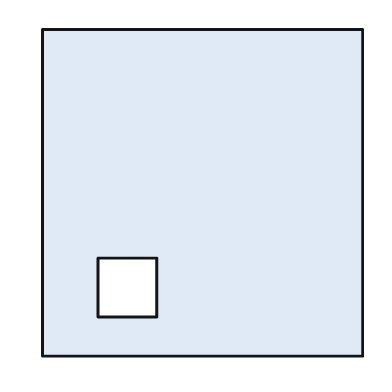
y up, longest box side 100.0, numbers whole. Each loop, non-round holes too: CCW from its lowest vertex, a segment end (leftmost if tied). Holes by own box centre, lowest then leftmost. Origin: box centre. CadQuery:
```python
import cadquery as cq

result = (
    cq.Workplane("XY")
    .moveTo(-49.0, -50.0)
    .lineTo(49.0, -50.0)
    .lineTo(49.0, 50.0)
    .lineTo(-49.0, 50.0)
    .close()
    .moveTo(-32.0, -38.0)
    .lineTo(-14.0, -38.0)
    .lineTo(-14.0, -20.0)
    .lineTo(-32.0, -20.0)
    .close()
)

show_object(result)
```